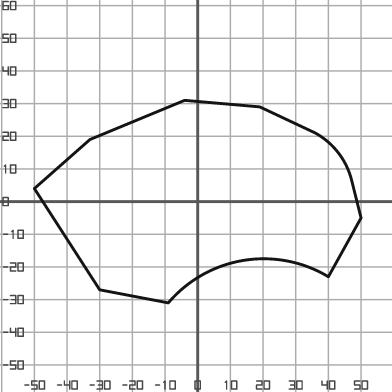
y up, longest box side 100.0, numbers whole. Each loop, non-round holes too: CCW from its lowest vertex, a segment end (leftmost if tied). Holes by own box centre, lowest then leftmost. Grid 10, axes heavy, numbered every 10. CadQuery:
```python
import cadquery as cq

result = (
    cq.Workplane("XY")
    .moveTo(-9.0, -31.0)
    .threePointArc((14.0, -18.0), (40.0, -23.0))
    .lineTo(50.0, -5.0)
    .lineTo(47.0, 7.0)
    .threePointArc((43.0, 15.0), (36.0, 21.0))
    .lineTo(19.0, 29.0)
    .lineTo(-4.0, 31.0)
    .lineTo(-33.0, 19.0)
    .lineTo(-50.0, 4.0)
    .lineTo(-30.0, -27.0)
    .close()
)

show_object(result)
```